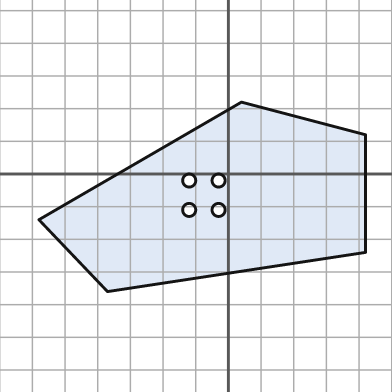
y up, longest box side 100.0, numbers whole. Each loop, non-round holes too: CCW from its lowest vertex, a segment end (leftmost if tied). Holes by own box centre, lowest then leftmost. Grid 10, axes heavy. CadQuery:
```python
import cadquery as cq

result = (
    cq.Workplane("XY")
    .moveTo(-37.0, -36.0)
    .lineTo(42.0, -24.0)
    .lineTo(42.0, 12.0)
    .lineTo(4.0, 22.0)
    .lineTo(-58.0, -14.0)
    .close()
    .moveTo(-12.0, -11.0)
    .circle(2.0)
    .moveTo(-3.0, -11.0)
    .circle(2.0)
    .moveTo(-12.0, -2.0)
    .circle(2.0)
    .moveTo(-3.0, -2.0)
    .circle(2.0)
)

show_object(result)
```